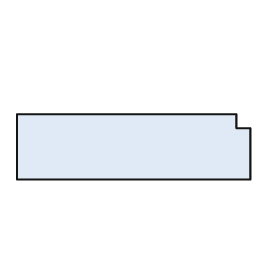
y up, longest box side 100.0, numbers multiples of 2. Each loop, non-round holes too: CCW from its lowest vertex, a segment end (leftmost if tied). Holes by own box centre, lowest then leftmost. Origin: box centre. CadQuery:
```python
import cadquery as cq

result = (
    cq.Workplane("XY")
    .moveTo(-50.0, -14.0)
    .lineTo(50.0, -14.0)
    .lineTo(50.0, 8.0)
    .lineTo(44.0, 8.0)
    .lineTo(44.0, 14.0)
    .lineTo(-50.0, 14.0)
    .close()
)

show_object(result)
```